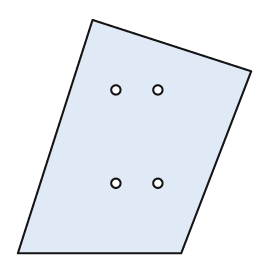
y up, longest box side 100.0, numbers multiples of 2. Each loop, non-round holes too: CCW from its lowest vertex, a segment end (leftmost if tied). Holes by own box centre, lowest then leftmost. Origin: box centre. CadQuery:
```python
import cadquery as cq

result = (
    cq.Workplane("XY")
    .moveTo(-50.0, -50.0)
    .lineTo(20.0, -50.0)
    .lineTo(50.0, 28.0)
    .lineTo(-18.0, 50.0)
    .close()
    .moveTo(-8.0, -20.0)
    .circle(2.0)
    .moveTo(10.0, -20.0)
    .circle(2.0)
    .moveTo(-8.0, 20.0)
    .circle(2.0)
    .moveTo(10.0, 20.0)
    .circle(2.0)
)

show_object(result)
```